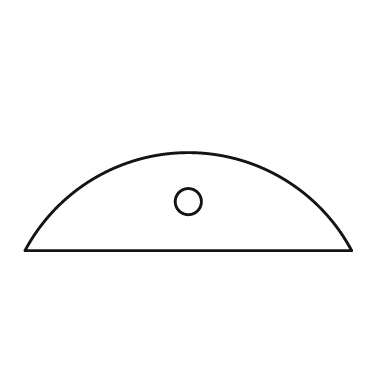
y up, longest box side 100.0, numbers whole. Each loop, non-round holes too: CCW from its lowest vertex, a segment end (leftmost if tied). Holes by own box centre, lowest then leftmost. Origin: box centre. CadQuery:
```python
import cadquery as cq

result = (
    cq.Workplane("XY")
    .moveTo(-50.0, -15.0)
    .lineTo(50.0, -15.0)
    .threePointArc((0.0, 15.0), (-50.0, -15.0))
    .close()
    .moveTo(0.0, 0.0)
    .circle(4.0)
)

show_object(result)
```